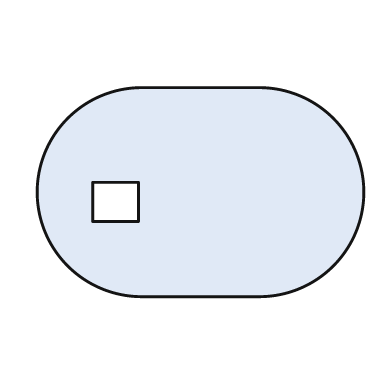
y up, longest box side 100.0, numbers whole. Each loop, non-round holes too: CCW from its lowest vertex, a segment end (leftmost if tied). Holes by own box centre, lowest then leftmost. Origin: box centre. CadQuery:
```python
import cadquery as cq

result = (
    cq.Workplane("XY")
    .moveTo(-18.0, -32.0)
    .lineTo(18.0, -32.0)
    .threePointArc((50.0, 0.0), (18.0, 32.0))
    .lineTo(-18.0, 32.0)
    .threePointArc((-50.0, 0.0), (-18.0, -32.0))
    .close()
    .moveTo(-33.0, -9.0)
    .lineTo(-19.0, -9.0)
    .lineTo(-19.0, 3.0)
    .lineTo(-33.0, 3.0)
    .close()
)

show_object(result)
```